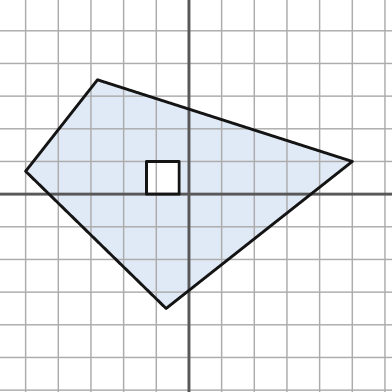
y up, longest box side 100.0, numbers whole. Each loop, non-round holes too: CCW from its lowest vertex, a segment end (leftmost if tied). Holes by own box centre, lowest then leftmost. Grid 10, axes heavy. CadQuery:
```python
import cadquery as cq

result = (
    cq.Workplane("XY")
    .moveTo(-7.0, -35.0)
    .lineTo(50.0, 10.0)
    .lineTo(-28.0, 35.0)
    .lineTo(-50.0, 7.0)
    .close()
    .moveTo(-13.0, 0.0)
    .lineTo(-3.0, 0.0)
    .lineTo(-3.0, 10.0)
    .lineTo(-13.0, 10.0)
    .close()
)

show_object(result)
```